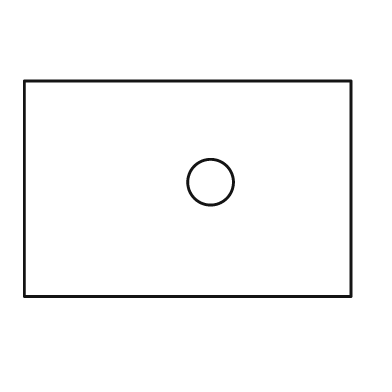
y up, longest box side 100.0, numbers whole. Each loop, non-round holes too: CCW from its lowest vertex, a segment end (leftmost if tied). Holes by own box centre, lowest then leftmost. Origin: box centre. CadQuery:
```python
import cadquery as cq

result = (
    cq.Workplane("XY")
    .moveTo(-50.0, -33.0)
    .lineTo(50.0, -33.0)
    .lineTo(50.0, 33.0)
    .lineTo(-50.0, 33.0)
    .close()
    .moveTo(7.0, 2.0)
    .circle(7.0)
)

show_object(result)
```